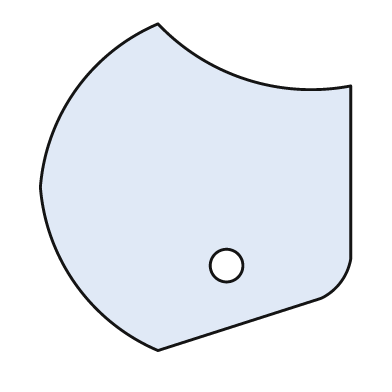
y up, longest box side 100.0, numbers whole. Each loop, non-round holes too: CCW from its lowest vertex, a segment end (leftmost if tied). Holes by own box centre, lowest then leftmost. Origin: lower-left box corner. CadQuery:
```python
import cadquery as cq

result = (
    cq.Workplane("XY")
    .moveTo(36.0, 0.0)
    .lineTo(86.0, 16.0)
    .threePointArc((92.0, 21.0), (95.0, 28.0))
    .lineTo(95.0, 81.0)
    .threePointArc((63.0, 83.0), (36.0, 100.0))
    .threePointArc((11.0, 80.0), (0.0, 50.0))
    .threePointArc((11.0, 20.0), (36.0, 0.0))
    .close()
    .moveTo(57.0, 26.0)
    .circle(5.0)
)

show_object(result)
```